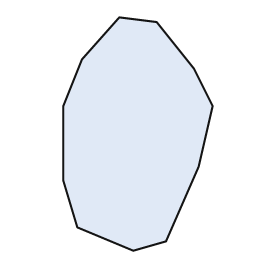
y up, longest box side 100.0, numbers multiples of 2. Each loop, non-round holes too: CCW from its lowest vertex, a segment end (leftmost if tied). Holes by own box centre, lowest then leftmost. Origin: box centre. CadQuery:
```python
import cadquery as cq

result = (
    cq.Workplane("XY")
    .moveTo(-2.0, -50.0)
    .lineTo(12.0, -46.0)
    .lineTo(26.0, -14.0)
    .lineTo(32.0, 12.0)
    .lineTo(24.0, 28.0)
    .lineTo(8.0, 48.0)
    .lineTo(-8.0, 50.0)
    .lineTo(-24.0, 32.0)
    .lineTo(-32.0, 12.0)
    .lineTo(-32.0, -20.0)
    .lineTo(-26.0, -40.0)
    .close()
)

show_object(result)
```